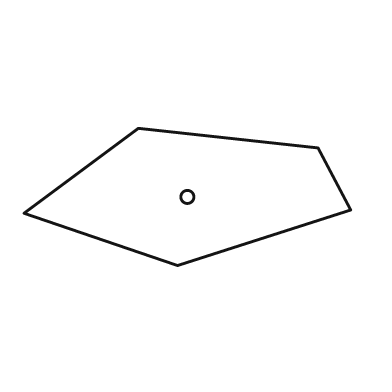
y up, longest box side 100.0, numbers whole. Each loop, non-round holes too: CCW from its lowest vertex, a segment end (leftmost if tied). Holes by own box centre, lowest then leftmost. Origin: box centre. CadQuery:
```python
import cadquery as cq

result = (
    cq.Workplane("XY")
    .moveTo(-3.0, -21.0)
    .lineTo(50.0, -4.0)
    .lineTo(40.0, 15.0)
    .lineTo(-15.0, 21.0)
    .lineTo(-50.0, -5.0)
    .close()
    .moveTo(0.0, 0.0)
    .circle(2.0)
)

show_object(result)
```